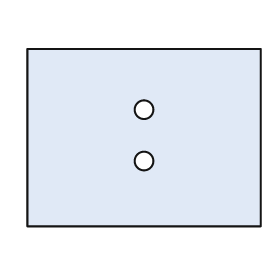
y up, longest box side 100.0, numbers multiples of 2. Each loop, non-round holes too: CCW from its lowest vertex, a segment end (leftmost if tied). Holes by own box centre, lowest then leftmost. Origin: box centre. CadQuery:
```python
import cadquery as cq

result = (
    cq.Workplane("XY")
    .moveTo(-50.0, -38.0)
    .lineTo(50.0, -38.0)
    .lineTo(50.0, 38.0)
    .lineTo(-50.0, 38.0)
    .close()
    .moveTo(0.0, -10.0)
    .circle(4.0)
    .moveTo(0.0, 12.0)
    .circle(4.0)
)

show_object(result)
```